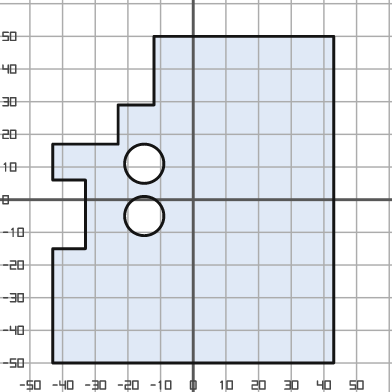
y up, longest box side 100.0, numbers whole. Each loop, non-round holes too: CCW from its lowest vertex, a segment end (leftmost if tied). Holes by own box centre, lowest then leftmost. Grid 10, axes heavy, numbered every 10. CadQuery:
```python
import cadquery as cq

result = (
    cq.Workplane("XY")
    .moveTo(-43.0, -50.0)
    .lineTo(43.0, -50.0)
    .lineTo(43.0, 50.0)
    .lineTo(-12.0, 50.0)
    .lineTo(-12.0, 29.0)
    .lineTo(-23.0, 29.0)
    .lineTo(-23.0, 17.0)
    .lineTo(-43.0, 17.0)
    .lineTo(-43.0, 6.0)
    .lineTo(-33.0, 6.0)
    .lineTo(-33.0, -15.0)
    .lineTo(-43.0, -15.0)
    .close()
    .moveTo(-15.0, -5.0)
    .circle(6.0)
    .moveTo(-15.0, 11.0)
    .circle(6.0)
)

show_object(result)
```